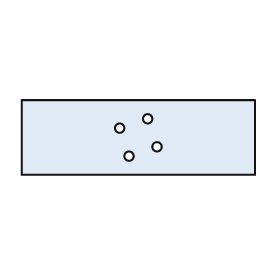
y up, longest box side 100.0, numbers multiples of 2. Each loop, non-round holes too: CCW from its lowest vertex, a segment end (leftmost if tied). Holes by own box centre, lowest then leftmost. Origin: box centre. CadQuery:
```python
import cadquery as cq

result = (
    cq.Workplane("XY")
    .moveTo(-50.0, -16.0)
    .lineTo(50.0, -16.0)
    .lineTo(50.0, 16.0)
    .lineTo(-50.0, 16.0)
    .close()
    .moveTo(-4.0, -8.0)
    .circle(2.0)
    .moveTo(8.0, -4.0)
    .circle(2.0)
    .moveTo(-8.0, 4.0)
    .circle(2.0)
    .moveTo(4.0, 8.0)
    .circle(2.0)
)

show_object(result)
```